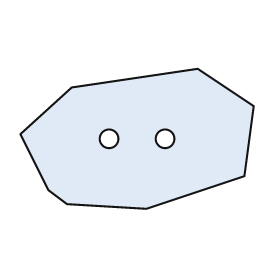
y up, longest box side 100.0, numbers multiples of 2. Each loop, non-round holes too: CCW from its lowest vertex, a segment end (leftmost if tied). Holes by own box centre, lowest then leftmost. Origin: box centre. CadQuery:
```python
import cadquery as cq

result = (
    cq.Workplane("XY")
    .moveTo(4.0, -30.0)
    .lineTo(46.0, -16.0)
    .lineTo(50.0, 14.0)
    .lineTo(26.0, 30.0)
    .lineTo(-28.0, 22.0)
    .lineTo(-50.0, 2.0)
    .lineTo(-38.0, -22.0)
    .lineTo(-30.0, -28.0)
    .close()
    .moveTo(-12.0, 0.0)
    .circle(4.0)
    .moveTo(12.0, 0.0)
    .circle(4.0)
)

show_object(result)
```